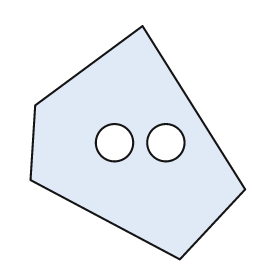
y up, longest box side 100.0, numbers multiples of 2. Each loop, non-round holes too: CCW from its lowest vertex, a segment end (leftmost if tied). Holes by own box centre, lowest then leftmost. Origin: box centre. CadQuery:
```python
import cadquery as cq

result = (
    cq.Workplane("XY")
    .moveTo(18.0, -50.0)
    .lineTo(46.0, -20.0)
    .lineTo(2.0, 50.0)
    .lineTo(-44.0, 16.0)
    .lineTo(-46.0, -16.0)
    .close()
    .moveTo(-10.0, 0.0)
    .circle(8.0)
    .moveTo(12.0, 0.0)
    .circle(8.0)
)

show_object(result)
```